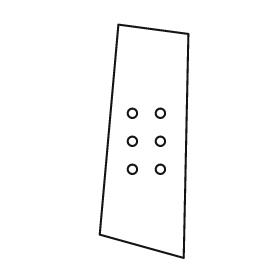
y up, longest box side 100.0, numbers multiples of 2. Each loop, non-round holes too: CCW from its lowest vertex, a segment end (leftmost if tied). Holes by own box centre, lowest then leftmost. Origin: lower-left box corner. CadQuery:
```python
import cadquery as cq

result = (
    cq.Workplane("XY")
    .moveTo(36.0, 0.0)
    .lineTo(38.0, 96.0)
    .lineTo(8.0, 100.0)
    .lineTo(0.0, 10.0)
    .close()
    .moveTo(14.0, 38.0)
    .circle(2.0)
    .moveTo(26.0, 38.0)
    .circle(2.0)
    .moveTo(14.0, 50.0)
    .circle(2.0)
    .moveTo(26.0, 50.0)
    .circle(2.0)
    .moveTo(14.0, 62.0)
    .circle(2.0)
    .moveTo(26.0, 62.0)
    .circle(2.0)
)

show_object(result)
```